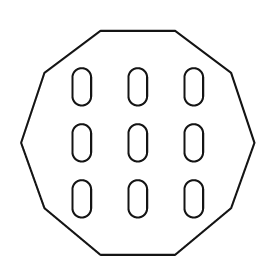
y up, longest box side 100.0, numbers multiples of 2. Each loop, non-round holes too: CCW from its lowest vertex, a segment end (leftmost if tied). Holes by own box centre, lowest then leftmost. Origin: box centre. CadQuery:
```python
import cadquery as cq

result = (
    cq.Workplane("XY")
    .moveTo(-16.0, -48.0)
    .lineTo(16.0, -48.0)
    .lineTo(40.0, -28.0)
    .lineTo(50.0, 0.0)
    .lineTo(40.0, 30.0)
    .lineTo(16.0, 48.0)
    .lineTo(-16.0, 48.0)
    .lineTo(-40.0, 30.0)
    .lineTo(-50.0, 0.0)
    .lineTo(-40.0, -28.0)
    .close()
    .moveTo(-28.0, -28.0)
    .threePointArc((-24.0, -32.0), (-20.0, -28.0))
    .lineTo(-20.0, -20.0)
    .threePointArc((-24.0, -16.0), (-28.0, -20.0))
    .close()
    .moveTo(-4.0, -28.0)
    .threePointArc((0.0, -32.0), (4.0, -28.0))
    .lineTo(4.0, -20.0)
    .threePointArc((0.0, -16.0), (-4.0, -20.0))
    .close()
    .moveTo(20.0, -28.0)
    .threePointArc((24.0, -32.0), (28.0, -28.0))
    .lineTo(28.0, -20.0)
    .threePointArc((24.0, -16.0), (20.0, -20.0))
    .close()
    .moveTo(-28.0, -4.0)
    .threePointArc((-24.0, -8.0), (-20.0, -4.0))
    .lineTo(-20.0, 4.0)
    .threePointArc((-24.0, 8.0), (-28.0, 4.0))
    .close()
    .moveTo(-4.0, -4.0)
    .threePointArc((0.0, -8.0), (4.0, -4.0))
    .lineTo(4.0, 4.0)
    .threePointArc((0.0, 8.0), (-4.0, 4.0))
    .close()
    .moveTo(20.0, -4.0)
    .threePointArc((24.0, -8.0), (28.0, -4.0))
    .lineTo(28.0, 4.0)
    .threePointArc((24.0, 8.0), (20.0, 4.0))
    .close()
    .moveTo(-28.0, 20.0)
    .threePointArc((-24.0, 16.0), (-20.0, 20.0))
    .lineTo(-20.0, 28.0)
    .threePointArc((-24.0, 32.0), (-28.0, 28.0))
    .close()
    .moveTo(-4.0, 20.0)
    .threePointArc((0.0, 16.0), (4.0, 20.0))
    .lineTo(4.0, 28.0)
    .threePointArc((0.0, 32.0), (-4.0, 28.0))
    .close()
    .moveTo(20.0, 20.0)
    .threePointArc((24.0, 16.0), (28.0, 20.0))
    .lineTo(28.0, 28.0)
    .threePointArc((24.0, 32.0), (20.0, 28.0))
    .close()
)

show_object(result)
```